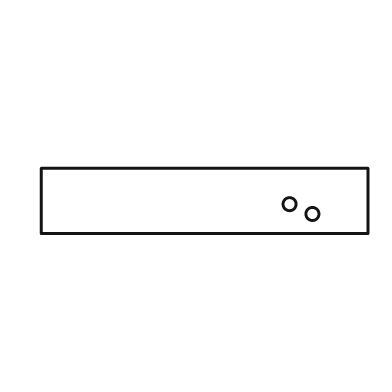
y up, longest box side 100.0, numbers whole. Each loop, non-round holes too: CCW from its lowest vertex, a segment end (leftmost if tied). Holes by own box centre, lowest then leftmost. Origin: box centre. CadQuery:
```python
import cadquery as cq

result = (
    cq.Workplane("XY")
    .moveTo(-50.0, -10.0)
    .lineTo(50.0, -10.0)
    .lineTo(50.0, 10.0)
    .lineTo(-50.0, 10.0)
    .close()
    .moveTo(33.0, -4.0)
    .circle(2.0)
    .moveTo(26.0, -1.0)
    .circle(2.0)
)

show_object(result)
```